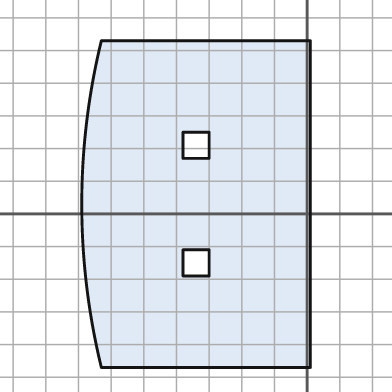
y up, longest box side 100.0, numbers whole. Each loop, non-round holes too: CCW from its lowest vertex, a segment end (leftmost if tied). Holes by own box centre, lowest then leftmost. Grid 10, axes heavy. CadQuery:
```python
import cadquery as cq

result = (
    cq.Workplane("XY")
    .moveTo(-63.0, -47.0)
    .lineTo(1.0, -47.0)
    .lineTo(1.0, 53.0)
    .lineTo(-63.0, 53.0)
    .threePointArc((-69.0, 3.0), (-63.0, -47.0))
    .close()
    .moveTo(-38.0, -19.0)
    .lineTo(-30.0, -19.0)
    .lineTo(-30.0, -11.0)
    .lineTo(-38.0, -11.0)
    .close()
    .moveTo(-38.0, 17.0)
    .lineTo(-30.0, 17.0)
    .lineTo(-30.0, 25.0)
    .lineTo(-38.0, 25.0)
    .close()
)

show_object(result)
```